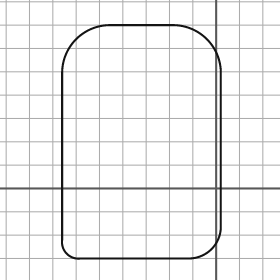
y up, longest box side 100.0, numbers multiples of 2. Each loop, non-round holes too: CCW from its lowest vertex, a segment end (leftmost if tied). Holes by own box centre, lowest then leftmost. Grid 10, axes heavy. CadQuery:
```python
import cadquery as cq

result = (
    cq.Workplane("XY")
    .moveTo(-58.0, -30.0)
    .lineTo(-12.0, -30.0)
    .threePointArc((-2.0, -26.0), (2.0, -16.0))
    .lineTo(2.0, 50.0)
    .threePointArc((-4.0, 64.0), (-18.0, 70.0))
    .lineTo(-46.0, 70.0)
    .threePointArc((-60.0, 64.0), (-66.0, 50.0))
    .lineTo(-66.0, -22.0)
    .threePointArc((-64.0, -28.0), (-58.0, -30.0))
    .close()
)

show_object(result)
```